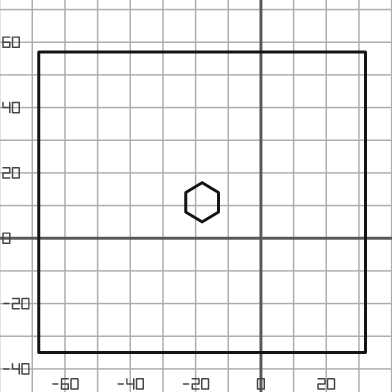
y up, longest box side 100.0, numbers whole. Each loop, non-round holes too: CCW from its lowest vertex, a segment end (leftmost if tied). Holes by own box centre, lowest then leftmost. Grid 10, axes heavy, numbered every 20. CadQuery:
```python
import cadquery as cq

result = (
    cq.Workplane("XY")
    .moveTo(-68.0, -35.0)
    .lineTo(32.0, -35.0)
    .lineTo(32.0, 57.0)
    .lineTo(-68.0, 57.0)
    .close()
    .moveTo(-18.0, 5.0)
    .lineTo(-13.0, 8.0)
    .lineTo(-13.0, 14.0)
    .lineTo(-18.0, 17.0)
    .lineTo(-23.0, 14.0)
    .lineTo(-23.0, 8.0)
    .close()
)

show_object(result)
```